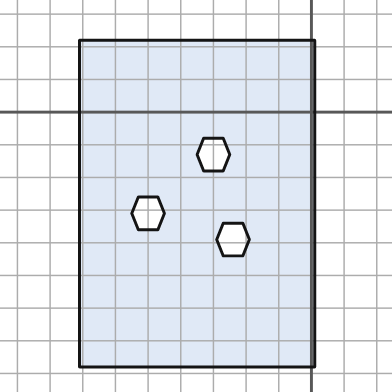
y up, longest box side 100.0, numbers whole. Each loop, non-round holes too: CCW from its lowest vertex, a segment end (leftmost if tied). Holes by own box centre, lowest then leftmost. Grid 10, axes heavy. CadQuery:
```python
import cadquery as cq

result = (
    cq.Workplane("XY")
    .moveTo(-71.0, -78.0)
    .lineTo(1.0, -78.0)
    .lineTo(1.0, 22.0)
    .lineTo(-71.0, 22.0)
    .close()
    .moveTo(-27.0, -44.0)
    .lineTo(-21.0, -44.0)
    .lineTo(-19.0, -39.0)
    .lineTo(-21.0, -34.0)
    .lineTo(-27.0, -34.0)
    .lineTo(-29.0, -39.0)
    .close()
    .moveTo(-53.0, -36.0)
    .lineTo(-47.0, -36.0)
    .lineTo(-45.0, -31.0)
    .lineTo(-47.0, -26.0)
    .lineTo(-53.0, -26.0)
    .lineTo(-55.0, -31.0)
    .close()
    .moveTo(-33.0, -18.0)
    .lineTo(-27.0, -18.0)
    .lineTo(-25.0, -13.0)
    .lineTo(-27.0, -8.0)
    .lineTo(-33.0, -8.0)
    .lineTo(-35.0, -13.0)
    .close()
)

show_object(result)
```